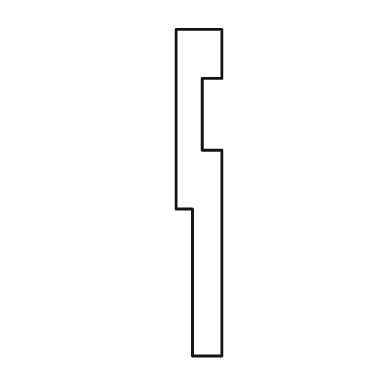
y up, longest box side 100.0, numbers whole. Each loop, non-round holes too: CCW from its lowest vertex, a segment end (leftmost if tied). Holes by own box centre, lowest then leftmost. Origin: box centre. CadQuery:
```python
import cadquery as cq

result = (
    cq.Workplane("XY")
    .moveTo(-2.0, -50.0)
    .lineTo(7.0, -50.0)
    .lineTo(7.0, 13.0)
    .lineTo(1.0, 13.0)
    .lineTo(1.0, 35.0)
    .lineTo(7.0, 35.0)
    .lineTo(7.0, 50.0)
    .lineTo(-7.0, 50.0)
    .lineTo(-7.0, -5.0)
    .lineTo(-2.0, -5.0)
    .close()
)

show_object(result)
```